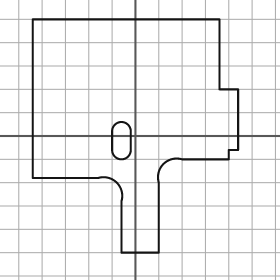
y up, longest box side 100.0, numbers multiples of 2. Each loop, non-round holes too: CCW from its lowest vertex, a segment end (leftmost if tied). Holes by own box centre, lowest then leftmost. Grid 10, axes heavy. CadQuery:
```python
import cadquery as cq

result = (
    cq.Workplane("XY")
    .moveTo(-6.0, -50.0)
    .lineTo(10.0, -50.0)
    .lineTo(10.0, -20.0)
    .threePointArc((12.0, -12.0), (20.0, -10.0))
    .lineTo(40.0, -10.0)
    .lineTo(40.0, -6.0)
    .lineTo(44.0, -6.0)
    .lineTo(44.0, 20.0)
    .lineTo(36.0, 20.0)
    .lineTo(36.0, 50.0)
    .lineTo(-44.0, 50.0)
    .lineTo(-44.0, -18.0)
    .lineTo(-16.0, -18.0)
    .threePointArc((-8.0, -20.0), (-6.0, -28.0))
    .close()
    .moveTo(-10.0, -6.0)
    .threePointArc((-6.0, -10.0), (-2.0, -6.0))
    .lineTo(-2.0, 2.0)
    .threePointArc((-6.0, 6.0), (-10.0, 2.0))
    .close()
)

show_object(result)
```